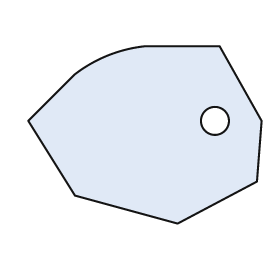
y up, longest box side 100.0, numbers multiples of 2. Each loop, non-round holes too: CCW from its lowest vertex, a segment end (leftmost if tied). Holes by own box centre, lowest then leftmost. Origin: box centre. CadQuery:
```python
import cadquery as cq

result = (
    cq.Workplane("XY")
    .moveTo(14.0, -38.0)
    .lineTo(48.0, -20.0)
    .lineTo(50.0, 6.0)
    .lineTo(32.0, 38.0)
    .lineTo(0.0, 38.0)
    .threePointArc((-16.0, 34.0), (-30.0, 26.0))
    .lineTo(-50.0, 6.0)
    .lineTo(-30.0, -26.0)
    .close()
    .moveTo(30.0, 6.0)
    .circle(6.0)
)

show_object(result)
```